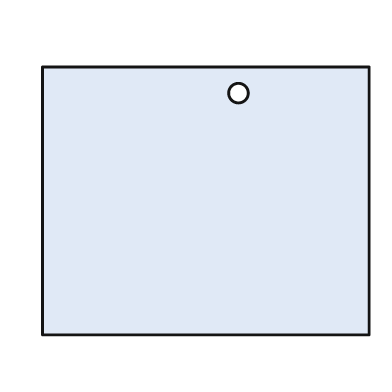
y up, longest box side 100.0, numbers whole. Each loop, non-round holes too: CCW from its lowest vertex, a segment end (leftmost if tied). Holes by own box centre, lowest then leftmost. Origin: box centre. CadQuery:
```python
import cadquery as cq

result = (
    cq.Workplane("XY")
    .moveTo(-50.0, -41.0)
    .lineTo(50.0, -41.0)
    .lineTo(50.0, 41.0)
    .lineTo(-50.0, 41.0)
    .close()
    .moveTo(10.0, 33.0)
    .circle(3.0)
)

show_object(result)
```